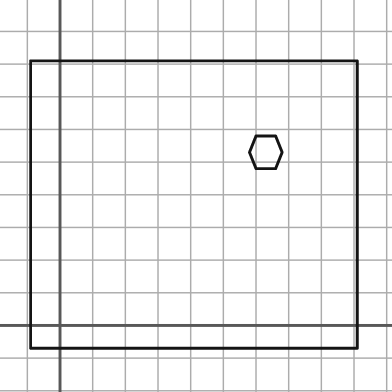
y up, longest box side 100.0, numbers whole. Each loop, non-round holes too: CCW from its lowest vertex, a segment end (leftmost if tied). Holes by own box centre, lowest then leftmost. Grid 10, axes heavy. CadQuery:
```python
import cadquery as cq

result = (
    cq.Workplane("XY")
    .moveTo(-9.0, -7.0)
    .lineTo(91.0, -7.0)
    .lineTo(91.0, 81.0)
    .lineTo(-9.0, 81.0)
    .close()
    .moveTo(60.0, 48.0)
    .lineTo(66.0, 48.0)
    .lineTo(68.0, 53.0)
    .lineTo(66.0, 58.0)
    .lineTo(60.0, 58.0)
    .lineTo(58.0, 53.0)
    .close()
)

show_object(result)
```